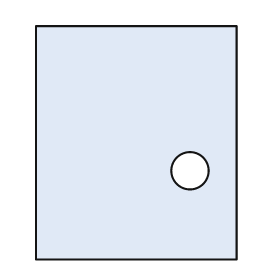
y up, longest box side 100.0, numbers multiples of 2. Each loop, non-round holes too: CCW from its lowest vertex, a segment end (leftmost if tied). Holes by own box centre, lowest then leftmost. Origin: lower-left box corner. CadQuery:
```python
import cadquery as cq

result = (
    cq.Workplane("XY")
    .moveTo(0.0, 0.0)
    .lineTo(86.0, 0.0)
    .lineTo(86.0, 100.0)
    .lineTo(0.0, 100.0)
    .close()
    .moveTo(66.0, 38.0)
    .circle(8.0)
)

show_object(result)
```